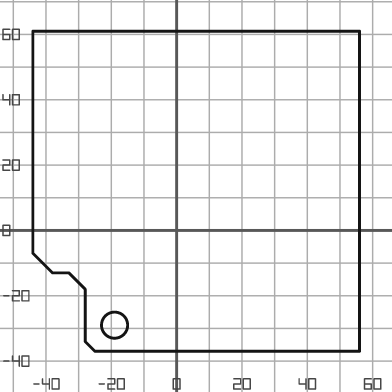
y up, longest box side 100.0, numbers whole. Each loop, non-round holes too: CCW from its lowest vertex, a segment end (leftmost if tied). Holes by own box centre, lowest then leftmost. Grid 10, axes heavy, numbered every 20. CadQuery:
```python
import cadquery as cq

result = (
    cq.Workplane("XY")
    .moveTo(-25.0, -37.0)
    .lineTo(56.0, -37.0)
    .lineTo(56.0, 61.0)
    .lineTo(-44.0, 61.0)
    .lineTo(-44.0, -7.0)
    .lineTo(-38.0, -13.0)
    .lineTo(-33.0, -13.0)
    .lineTo(-28.0, -18.0)
    .lineTo(-28.0, -34.0)
    .close()
    .moveTo(-19.0, -29.0)
    .circle(4.0)
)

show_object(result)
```